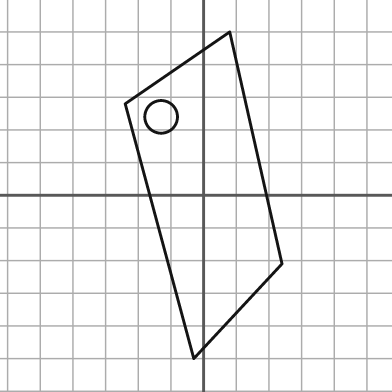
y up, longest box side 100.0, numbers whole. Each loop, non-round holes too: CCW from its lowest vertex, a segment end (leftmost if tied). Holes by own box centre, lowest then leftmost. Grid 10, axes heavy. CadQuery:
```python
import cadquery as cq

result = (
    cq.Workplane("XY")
    .moveTo(-3.0, -50.0)
    .lineTo(24.0, -21.0)
    .lineTo(8.0, 50.0)
    .lineTo(-24.0, 28.0)
    .close()
    .moveTo(-13.0, 24.0)
    .circle(5.0)
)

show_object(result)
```